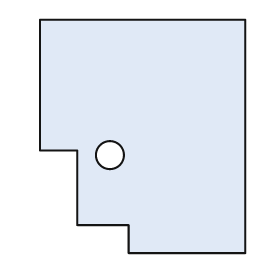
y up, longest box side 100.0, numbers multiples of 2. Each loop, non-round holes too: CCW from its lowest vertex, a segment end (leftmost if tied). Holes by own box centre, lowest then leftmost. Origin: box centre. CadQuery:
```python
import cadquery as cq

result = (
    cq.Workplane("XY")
    .moveTo(-6.0, -50.0)
    .lineTo(44.0, -50.0)
    .lineTo(44.0, 50.0)
    .lineTo(-44.0, 50.0)
    .lineTo(-44.0, -6.0)
    .lineTo(-28.0, -6.0)
    .lineTo(-28.0, -38.0)
    .lineTo(-6.0, -38.0)
    .close()
    .moveTo(-14.0, -8.0)
    .circle(6.0)
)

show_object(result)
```